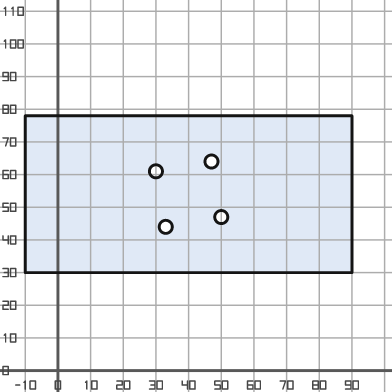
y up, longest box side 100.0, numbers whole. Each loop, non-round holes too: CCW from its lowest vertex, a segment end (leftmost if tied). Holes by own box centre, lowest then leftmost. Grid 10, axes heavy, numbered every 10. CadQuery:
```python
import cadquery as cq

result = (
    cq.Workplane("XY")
    .moveTo(-10.0, 30.0)
    .lineTo(90.0, 30.0)
    .lineTo(90.0, 78.0)
    .lineTo(-10.0, 78.0)
    .close()
    .moveTo(33.0, 44.0)
    .circle(2.0)
    .moveTo(50.0, 47.0)
    .circle(2.0)
    .moveTo(30.0, 61.0)
    .circle(2.0)
    .moveTo(47.0, 64.0)
    .circle(2.0)
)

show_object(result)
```